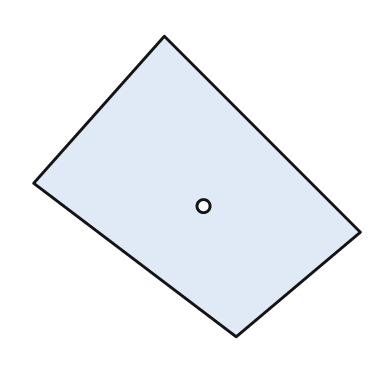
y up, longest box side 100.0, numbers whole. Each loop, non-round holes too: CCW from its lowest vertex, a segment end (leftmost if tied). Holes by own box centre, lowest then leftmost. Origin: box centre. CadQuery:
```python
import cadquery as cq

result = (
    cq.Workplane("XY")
    .moveTo(12.0, -46.0)
    .lineTo(50.0, -14.0)
    .lineTo(-10.0, 46.0)
    .lineTo(-50.0, 1.0)
    .close()
    .moveTo(2.0, -6.0)
    .circle(2.0)
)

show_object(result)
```